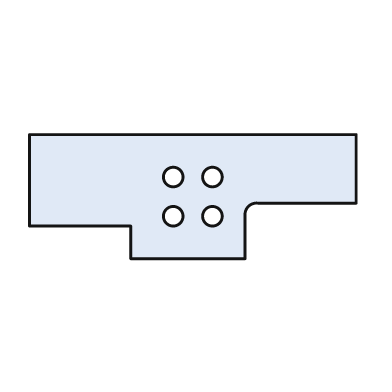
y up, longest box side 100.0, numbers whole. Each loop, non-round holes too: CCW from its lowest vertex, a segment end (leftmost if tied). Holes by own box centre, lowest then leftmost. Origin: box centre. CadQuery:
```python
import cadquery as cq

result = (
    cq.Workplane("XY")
    .moveTo(-19.0, -19.0)
    .lineTo(16.0, -19.0)
    .lineTo(16.0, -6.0)
    .threePointArc((17.0, -3.0), (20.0, -2.0))
    .lineTo(50.0, -2.0)
    .lineTo(50.0, 19.0)
    .lineTo(-50.0, 19.0)
    .lineTo(-50.0, -9.0)
    .lineTo(-19.0, -9.0)
    .close()
    .moveTo(-6.0, -6.0)
    .circle(3.0)
    .moveTo(6.0, -6.0)
    .circle(3.0)
    .moveTo(-6.0, 6.0)
    .circle(3.0)
    .moveTo(6.0, 6.0)
    .circle(3.0)
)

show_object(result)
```